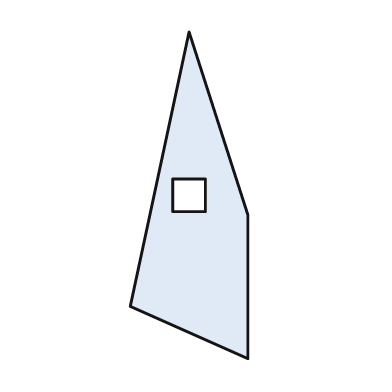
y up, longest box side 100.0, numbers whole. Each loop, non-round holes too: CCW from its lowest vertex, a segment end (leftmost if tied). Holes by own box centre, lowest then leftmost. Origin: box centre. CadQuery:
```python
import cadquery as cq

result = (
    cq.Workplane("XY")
    .moveTo(18.0, -50.0)
    .lineTo(18.0, -6.0)
    .lineTo(0.0, 50.0)
    .lineTo(-18.0, -34.0)
    .close()
    .moveTo(-5.0, -5.0)
    .lineTo(5.0, -5.0)
    .lineTo(5.0, 5.0)
    .lineTo(-5.0, 5.0)
    .close()
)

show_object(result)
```